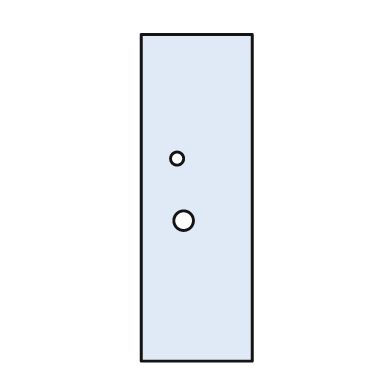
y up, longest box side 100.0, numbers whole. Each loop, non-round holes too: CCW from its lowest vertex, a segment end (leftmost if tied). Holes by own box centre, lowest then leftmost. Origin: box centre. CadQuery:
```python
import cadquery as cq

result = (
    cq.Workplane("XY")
    .moveTo(-17.0, -50.0)
    .lineTo(17.0, -50.0)
    .lineTo(17.0, 50.0)
    .lineTo(-17.0, 50.0)
    .close()
    .moveTo(-4.0, -7.0)
    .circle(3.0)
    .moveTo(-6.0, 12.0)
    .circle(2.0)
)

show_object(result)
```